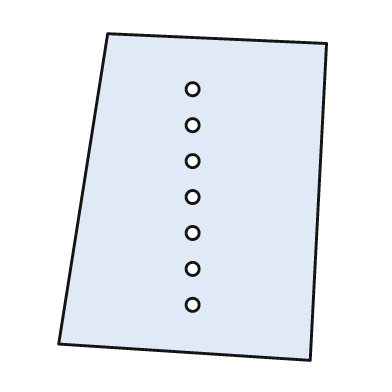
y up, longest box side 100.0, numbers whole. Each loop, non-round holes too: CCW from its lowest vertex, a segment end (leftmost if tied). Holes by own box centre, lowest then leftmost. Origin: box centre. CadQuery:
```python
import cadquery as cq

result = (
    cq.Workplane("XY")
    .moveTo(36.0, -50.0)
    .lineTo(41.0, 47.0)
    .lineTo(-26.0, 50.0)
    .lineTo(-41.0, -45.0)
    .close()
    .moveTo(0.0, -33.0)
    .circle(2.0)
    .moveTo(0.0, -22.0)
    .circle(2.0)
    .moveTo(0.0, -11.0)
    .circle(2.0)
    .moveTo(0.0, 0.0)
    .circle(2.0)
    .moveTo(0.0, 11.0)
    .circle(2.0)
    .moveTo(0.0, 22.0)
    .circle(2.0)
    .moveTo(0.0, 33.0)
    .circle(2.0)
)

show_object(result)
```